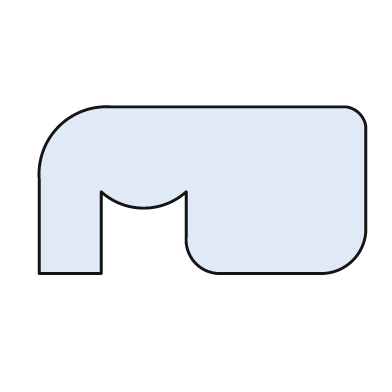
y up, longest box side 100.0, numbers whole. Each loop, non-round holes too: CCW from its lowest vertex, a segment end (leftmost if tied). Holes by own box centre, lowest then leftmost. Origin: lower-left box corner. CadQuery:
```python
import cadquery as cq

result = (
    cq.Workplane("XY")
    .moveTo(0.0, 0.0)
    .lineTo(19.0, 0.0)
    .lineTo(19.0, 25.0)
    .threePointArc((32.0, 20.0), (45.0, 25.0))
    .lineTo(45.0, 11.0)
    .threePointArc((48.0, 3.0), (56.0, 0.0))
    .lineTo(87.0, 0.0)
    .threePointArc((96.0, 4.0), (100.0, 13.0))
    .lineTo(100.0, 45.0)
    .threePointArc((98.0, 49.0), (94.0, 51.0))
    .lineTo(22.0, 51.0)
    .threePointArc((6.0, 45.0), (0.0, 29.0))
    .close()
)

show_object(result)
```